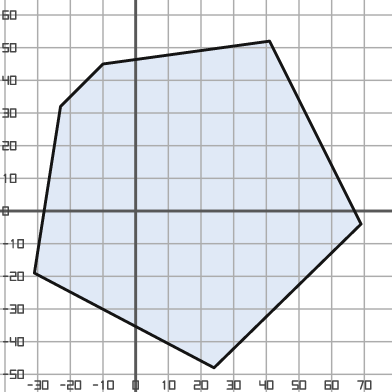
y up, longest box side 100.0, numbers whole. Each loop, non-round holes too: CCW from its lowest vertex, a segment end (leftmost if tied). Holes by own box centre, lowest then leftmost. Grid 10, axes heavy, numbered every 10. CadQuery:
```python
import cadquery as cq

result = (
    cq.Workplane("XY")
    .moveTo(24.0, -48.0)
    .lineTo(69.0, -4.0)
    .lineTo(41.0, 52.0)
    .lineTo(-10.0, 45.0)
    .lineTo(-23.0, 32.0)
    .lineTo(-31.0, -19.0)
    .close()
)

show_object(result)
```